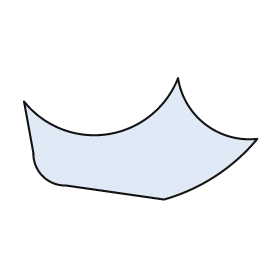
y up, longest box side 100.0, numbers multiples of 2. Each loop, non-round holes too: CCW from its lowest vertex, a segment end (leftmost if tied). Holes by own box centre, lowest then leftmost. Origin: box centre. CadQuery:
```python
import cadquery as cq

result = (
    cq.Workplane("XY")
    .moveTo(10.0, -26.0)
    .threePointArc((32.0, -16.0), (50.0, 0.0))
    .threePointArc((28.0, 6.0), (16.0, 26.0))
    .threePointArc((-14.0, 2.0), (-50.0, 16.0))
    .lineTo(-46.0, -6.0)
    .threePointArc((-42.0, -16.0), (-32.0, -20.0))
    .close()
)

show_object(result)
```